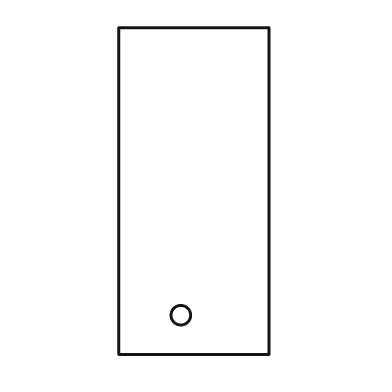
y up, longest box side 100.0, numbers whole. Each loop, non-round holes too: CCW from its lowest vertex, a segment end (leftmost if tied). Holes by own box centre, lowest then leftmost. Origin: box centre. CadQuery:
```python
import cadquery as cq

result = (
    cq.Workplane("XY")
    .moveTo(-23.0, -50.0)
    .lineTo(23.0, -50.0)
    .lineTo(23.0, 50.0)
    .lineTo(-23.0, 50.0)
    .close()
    .moveTo(-4.0, -38.0)
    .circle(3.0)
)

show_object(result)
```